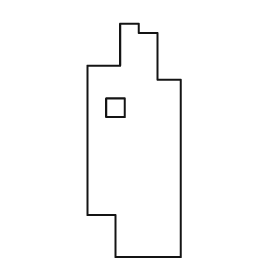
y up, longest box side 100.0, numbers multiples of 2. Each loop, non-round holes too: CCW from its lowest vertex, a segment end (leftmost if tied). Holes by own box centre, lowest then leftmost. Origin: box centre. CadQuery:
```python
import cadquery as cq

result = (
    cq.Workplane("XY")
    .moveTo(-8.0, -50.0)
    .lineTo(20.0, -50.0)
    .lineTo(20.0, 26.0)
    .lineTo(10.0, 26.0)
    .lineTo(10.0, 46.0)
    .lineTo(2.0, 46.0)
    .lineTo(2.0, 50.0)
    .lineTo(-6.0, 50.0)
    .lineTo(-6.0, 32.0)
    .lineTo(-20.0, 32.0)
    .lineTo(-20.0, -32.0)
    .lineTo(-8.0, -32.0)
    .close()
    .moveTo(-12.0, 10.0)
    .lineTo(-4.0, 10.0)
    .lineTo(-4.0, 18.0)
    .lineTo(-12.0, 18.0)
    .close()
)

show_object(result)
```